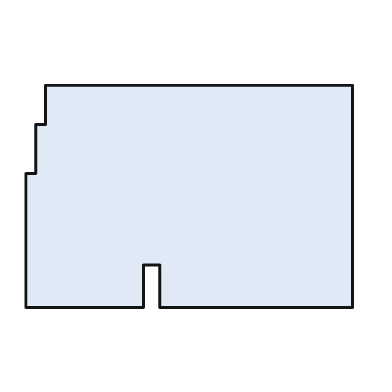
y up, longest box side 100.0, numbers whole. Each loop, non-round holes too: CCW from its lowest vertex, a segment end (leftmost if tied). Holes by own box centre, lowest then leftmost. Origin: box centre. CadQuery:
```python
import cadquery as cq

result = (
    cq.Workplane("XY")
    .moveTo(-50.0, -34.0)
    .lineTo(-14.0, -34.0)
    .lineTo(-14.0, -21.0)
    .lineTo(-9.0, -21.0)
    .lineTo(-9.0, -34.0)
    .lineTo(50.0, -34.0)
    .lineTo(50.0, 34.0)
    .lineTo(-44.0, 34.0)
    .lineTo(-44.0, 22.0)
    .lineTo(-47.0, 22.0)
    .lineTo(-47.0, 7.0)
    .lineTo(-50.0, 7.0)
    .close()
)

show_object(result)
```